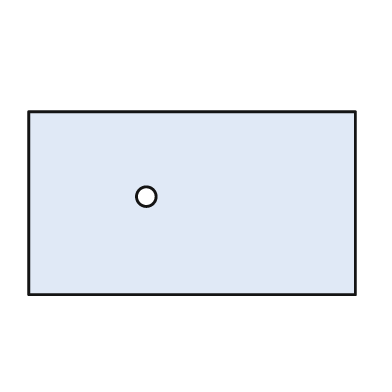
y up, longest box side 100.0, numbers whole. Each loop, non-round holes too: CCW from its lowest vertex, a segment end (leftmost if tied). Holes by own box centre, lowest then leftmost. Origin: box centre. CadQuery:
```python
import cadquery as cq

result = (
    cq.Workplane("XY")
    .moveTo(-50.0, -28.0)
    .lineTo(50.0, -28.0)
    .lineTo(50.0, 28.0)
    .lineTo(-50.0, 28.0)
    .close()
    .moveTo(-14.0, 2.0)
    .circle(3.0)
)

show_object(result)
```